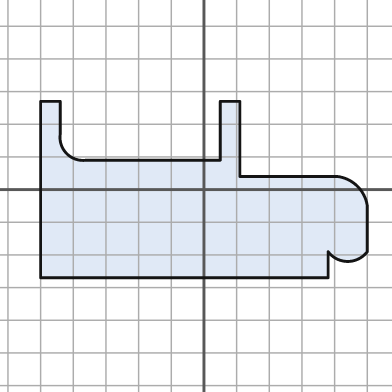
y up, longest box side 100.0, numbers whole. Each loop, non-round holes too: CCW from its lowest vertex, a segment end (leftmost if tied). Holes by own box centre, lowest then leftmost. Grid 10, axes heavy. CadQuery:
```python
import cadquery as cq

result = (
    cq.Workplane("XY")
    .moveTo(-50.0, -27.0)
    .lineTo(38.0, -27.0)
    .lineTo(38.0, -19.0)
    .threePointArc((44.0, -22.0), (50.0, -19.0))
    .lineTo(50.0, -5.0)
    .threePointArc((47.0, 1.0), (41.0, 4.0))
    .lineTo(11.0, 4.0)
    .lineTo(11.0, 27.0)
    .lineTo(5.0, 27.0)
    .lineTo(5.0, 9.0)
    .lineTo(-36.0, 9.0)
    .threePointArc((-42.0, 11.0), (-44.0, 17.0))
    .lineTo(-44.0, 27.0)
    .lineTo(-50.0, 27.0)
    .close()
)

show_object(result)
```